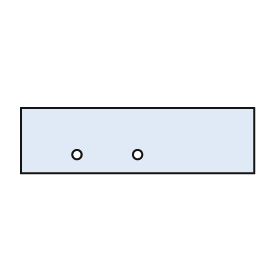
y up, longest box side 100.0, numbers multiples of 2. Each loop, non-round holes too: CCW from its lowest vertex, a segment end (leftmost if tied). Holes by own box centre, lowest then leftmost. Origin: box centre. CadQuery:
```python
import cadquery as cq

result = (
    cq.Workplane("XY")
    .moveTo(-50.0, -14.0)
    .lineTo(50.0, -14.0)
    .lineTo(50.0, 14.0)
    .lineTo(-50.0, 14.0)
    .close()
    .moveTo(-26.0, -6.0)
    .circle(2.0)
    .moveTo(0.0, -6.0)
    .circle(2.0)
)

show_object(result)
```